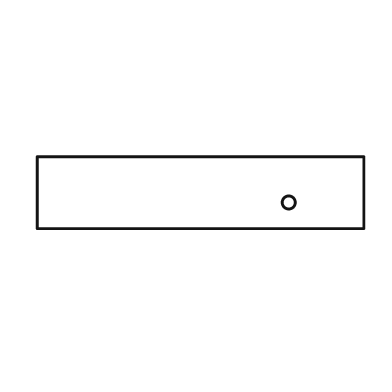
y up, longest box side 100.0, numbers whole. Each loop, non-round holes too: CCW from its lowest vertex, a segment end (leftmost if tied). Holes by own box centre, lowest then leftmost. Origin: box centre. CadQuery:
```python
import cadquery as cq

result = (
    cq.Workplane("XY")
    .moveTo(-50.0, -11.0)
    .lineTo(50.0, -11.0)
    .lineTo(50.0, 11.0)
    .lineTo(-50.0, 11.0)
    .close()
    .moveTo(27.0, -3.0)
    .circle(2.0)
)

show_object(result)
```